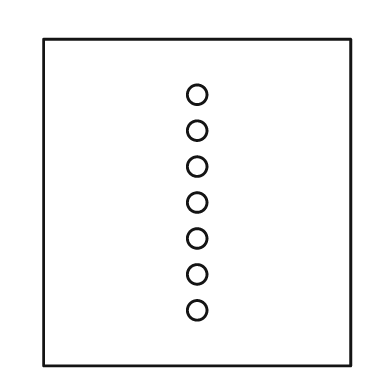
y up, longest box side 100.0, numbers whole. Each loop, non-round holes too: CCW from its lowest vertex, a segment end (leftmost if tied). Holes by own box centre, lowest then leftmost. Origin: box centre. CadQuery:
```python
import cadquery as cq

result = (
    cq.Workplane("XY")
    .moveTo(-47.0, -50.0)
    .lineTo(47.0, -50.0)
    .lineTo(47.0, 50.0)
    .lineTo(-47.0, 50.0)
    .close()
    .moveTo(0.0, -33.0)
    .circle(3.0)
    .moveTo(0.0, -22.0)
    .circle(3.0)
    .moveTo(0.0, -11.0)
    .circle(3.0)
    .moveTo(0.0, 0.0)
    .circle(3.0)
    .moveTo(0.0, 11.0)
    .circle(3.0)
    .moveTo(0.0, 22.0)
    .circle(3.0)
    .moveTo(0.0, 33.0)
    .circle(3.0)
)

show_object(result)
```